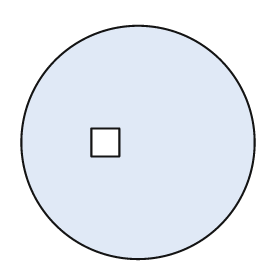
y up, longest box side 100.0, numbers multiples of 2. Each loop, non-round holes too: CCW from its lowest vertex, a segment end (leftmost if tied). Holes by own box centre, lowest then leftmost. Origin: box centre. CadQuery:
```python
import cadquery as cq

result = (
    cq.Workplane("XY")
    .moveTo(0.0, 0.0)
    .circle(50.0)
    .moveTo(-20.0, -6.0)
    .lineTo(-8.0, -6.0)
    .lineTo(-8.0, 6.0)
    .lineTo(-20.0, 6.0)
    .close()
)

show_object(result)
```